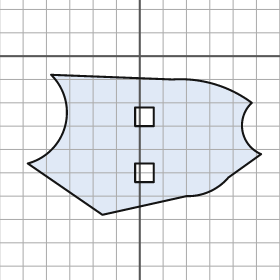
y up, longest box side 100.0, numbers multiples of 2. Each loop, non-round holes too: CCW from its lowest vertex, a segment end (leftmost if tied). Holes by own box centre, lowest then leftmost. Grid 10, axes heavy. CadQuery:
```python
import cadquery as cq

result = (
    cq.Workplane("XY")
    .moveTo(-16.0, -68.0)
    .lineTo(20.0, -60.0)
    .threePointArc((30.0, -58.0), (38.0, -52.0))
    .lineTo(52.0, -42.0)
    .threePointArc((44.0, -32.0), (48.0, -20.0))
    .threePointArc((32.0, -12.0), (14.0, -10.0))
    .lineTo(-38.0, -8.0)
    .threePointArc((-32.0, -30.0), (-48.0, -46.0))
    .close()
    .moveTo(-2.0, -54.0)
    .lineTo(6.0, -54.0)
    .lineTo(6.0, -46.0)
    .lineTo(-2.0, -46.0)
    .close()
    .moveTo(-2.0, -30.0)
    .lineTo(6.0, -30.0)
    .lineTo(6.0, -22.0)
    .lineTo(-2.0, -22.0)
    .close()
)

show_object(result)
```